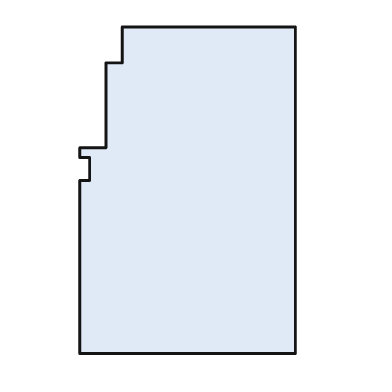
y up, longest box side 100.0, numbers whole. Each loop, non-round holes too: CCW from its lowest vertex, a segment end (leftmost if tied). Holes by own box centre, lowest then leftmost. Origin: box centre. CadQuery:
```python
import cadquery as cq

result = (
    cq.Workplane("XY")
    .moveTo(-33.0, -50.0)
    .lineTo(33.0, -50.0)
    .lineTo(33.0, 50.0)
    .lineTo(-20.0, 50.0)
    .lineTo(-20.0, 39.0)
    .lineTo(-25.0, 39.0)
    .lineTo(-25.0, 13.0)
    .lineTo(-33.0, 13.0)
    .lineTo(-33.0, 10.0)
    .lineTo(-30.0, 10.0)
    .lineTo(-30.0, 3.0)
    .lineTo(-33.0, 3.0)
    .close()
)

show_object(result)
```